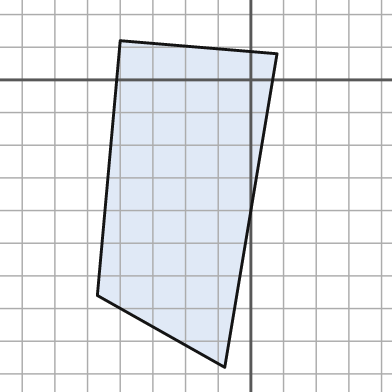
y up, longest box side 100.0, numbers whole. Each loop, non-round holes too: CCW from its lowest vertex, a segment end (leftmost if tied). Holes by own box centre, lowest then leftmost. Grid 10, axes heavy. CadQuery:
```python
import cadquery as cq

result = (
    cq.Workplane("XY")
    .moveTo(-8.0, -88.0)
    .lineTo(8.0, 8.0)
    .lineTo(-40.0, 12.0)
    .lineTo(-47.0, -66.0)
    .close()
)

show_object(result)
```